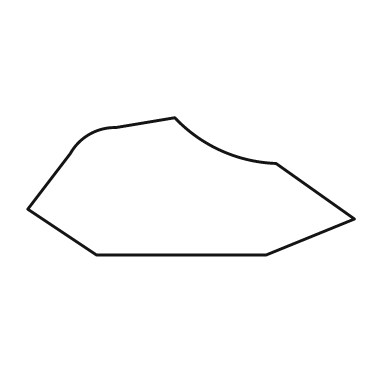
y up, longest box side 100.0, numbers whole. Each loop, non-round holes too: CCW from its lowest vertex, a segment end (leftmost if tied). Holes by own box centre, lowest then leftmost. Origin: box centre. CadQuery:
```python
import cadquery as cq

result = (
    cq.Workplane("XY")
    .moveTo(-29.0, -21.0)
    .lineTo(23.0, -21.0)
    .lineTo(50.0, -10.0)
    .lineTo(26.0, 7.0)
    .threePointArc((9.0, 11.0), (-5.0, 21.0))
    .lineTo(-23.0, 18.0)
    .threePointArc((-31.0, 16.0), (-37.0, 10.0))
    .lineTo(-50.0, -7.0)
    .close()
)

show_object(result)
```